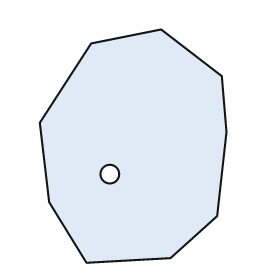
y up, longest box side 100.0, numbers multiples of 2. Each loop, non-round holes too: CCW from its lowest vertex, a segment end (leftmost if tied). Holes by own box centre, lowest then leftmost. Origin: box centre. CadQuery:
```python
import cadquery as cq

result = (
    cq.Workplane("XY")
    .moveTo(-20.0, -50.0)
    .lineTo(16.0, -48.0)
    .lineTo(36.0, -30.0)
    .lineTo(40.0, 6.0)
    .lineTo(38.0, 30.0)
    .lineTo(12.0, 50.0)
    .lineTo(-18.0, 44.0)
    .lineTo(-40.0, 10.0)
    .lineTo(-36.0, -24.0)
    .close()
    .moveTo(-10.0, -12.0)
    .circle(4.0)
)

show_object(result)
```